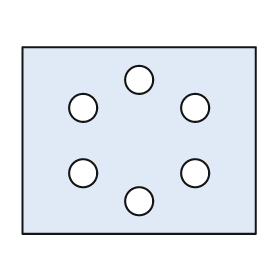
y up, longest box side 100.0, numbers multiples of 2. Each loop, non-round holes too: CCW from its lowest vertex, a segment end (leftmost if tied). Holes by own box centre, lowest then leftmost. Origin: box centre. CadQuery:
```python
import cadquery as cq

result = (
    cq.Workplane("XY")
    .moveTo(-50.0, -40.0)
    .lineTo(50.0, -40.0)
    .lineTo(50.0, 40.0)
    .lineTo(-50.0, 40.0)
    .close()
    .moveTo(0.0, -26.0)
    .circle(6.0)
    .moveTo(-24.0, -14.0)
    .circle(6.0)
    .moveTo(24.0, -14.0)
    .circle(6.0)
    .moveTo(-24.0, 14.0)
    .circle(6.0)
    .moveTo(24.0, 14.0)
    .circle(6.0)
    .moveTo(0.0, 26.0)
    .circle(6.0)
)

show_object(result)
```